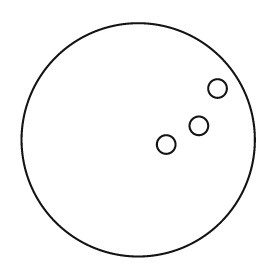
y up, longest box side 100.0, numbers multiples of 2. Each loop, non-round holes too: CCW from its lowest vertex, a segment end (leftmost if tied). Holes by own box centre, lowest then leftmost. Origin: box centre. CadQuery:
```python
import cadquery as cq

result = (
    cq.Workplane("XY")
    .moveTo(0.0, 0.0)
    .circle(50.0)
    .moveTo(12.0, -2.0)
    .circle(4.0)
    .moveTo(26.0, 6.0)
    .circle(4.0)
    .moveTo(34.0, 22.0)
    .circle(4.0)
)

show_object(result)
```